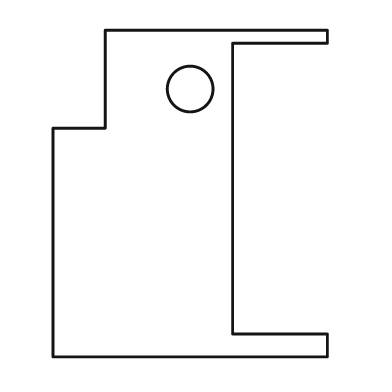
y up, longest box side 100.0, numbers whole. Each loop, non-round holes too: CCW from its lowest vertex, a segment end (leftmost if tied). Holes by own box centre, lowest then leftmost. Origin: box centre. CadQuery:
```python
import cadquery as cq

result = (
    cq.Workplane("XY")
    .moveTo(-42.0, -50.0)
    .lineTo(42.0, -50.0)
    .lineTo(42.0, -43.0)
    .lineTo(13.0, -43.0)
    .lineTo(13.0, 46.0)
    .lineTo(42.0, 46.0)
    .lineTo(42.0, 50.0)
    .lineTo(-26.0, 50.0)
    .lineTo(-26.0, 20.0)
    .lineTo(-42.0, 20.0)
    .close()
    .moveTo(0.0, 32.0)
    .circle(7.0)
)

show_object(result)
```